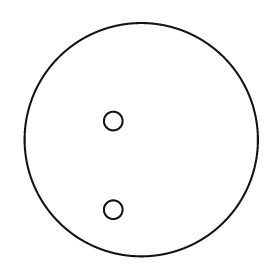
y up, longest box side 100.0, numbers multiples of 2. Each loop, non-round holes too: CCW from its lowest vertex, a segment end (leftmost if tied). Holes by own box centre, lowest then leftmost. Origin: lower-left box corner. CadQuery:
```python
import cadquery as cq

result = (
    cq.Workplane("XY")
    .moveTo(50.0, 50.0)
    .circle(50.0)
    .moveTo(38.0, 20.0)
    .circle(4.0)
    .moveTo(38.0, 58.0)
    .circle(4.0)
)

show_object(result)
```